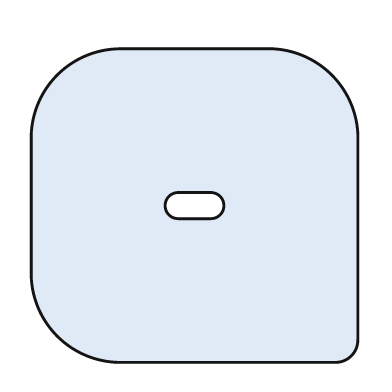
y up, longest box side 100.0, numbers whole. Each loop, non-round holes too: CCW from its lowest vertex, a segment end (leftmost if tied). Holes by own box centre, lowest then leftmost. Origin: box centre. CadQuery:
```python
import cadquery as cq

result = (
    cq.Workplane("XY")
    .moveTo(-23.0, -48.0)
    .lineTo(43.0, -48.0)
    .threePointArc((48.0, -46.0), (50.0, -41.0))
    .lineTo(50.0, 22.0)
    .threePointArc((42.0, 40.0), (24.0, 48.0))
    .lineTo(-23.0, 48.0)
    .threePointArc((-42.0, 40.0), (-50.0, 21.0))
    .lineTo(-50.0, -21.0)
    .threePointArc((-42.0, -40.0), (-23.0, -48.0))
    .close()
    .moveTo(-5.0, -4.0)
    .lineTo(5.0, -4.0)
    .threePointArc((9.0, 0.0), (5.0, 4.0))
    .lineTo(-5.0, 4.0)
    .threePointArc((-9.0, 0.0), (-5.0, -4.0))
    .close()
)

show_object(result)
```